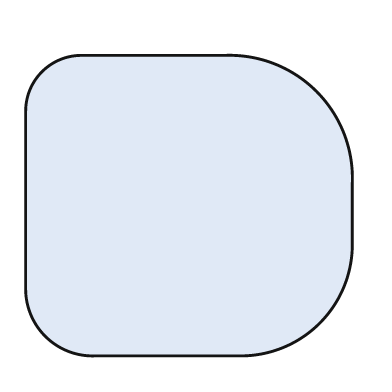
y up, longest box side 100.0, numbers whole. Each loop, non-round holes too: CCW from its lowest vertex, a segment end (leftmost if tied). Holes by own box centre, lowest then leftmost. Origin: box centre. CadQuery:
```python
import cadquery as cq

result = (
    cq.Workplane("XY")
    .moveTo(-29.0, -46.0)
    .lineTo(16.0, -46.0)
    .threePointArc((40.0, -36.0), (50.0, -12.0))
    .lineTo(50.0, 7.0)
    .threePointArc((39.0, 35.0), (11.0, 46.0))
    .lineTo(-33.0, 46.0)
    .threePointArc((-45.0, 41.0), (-50.0, 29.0))
    .lineTo(-50.0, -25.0)
    .threePointArc((-44.0, -40.0), (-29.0, -46.0))
    .close()
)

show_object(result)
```